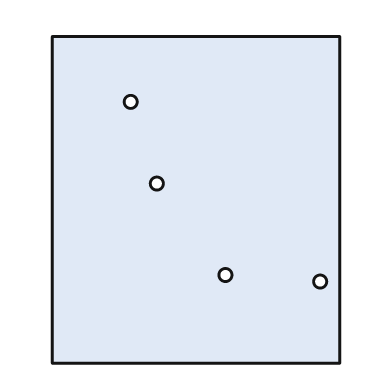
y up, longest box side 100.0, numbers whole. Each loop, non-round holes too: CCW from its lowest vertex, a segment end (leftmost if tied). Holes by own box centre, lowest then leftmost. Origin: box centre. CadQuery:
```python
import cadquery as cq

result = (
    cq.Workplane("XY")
    .moveTo(-44.0, -50.0)
    .lineTo(44.0, -50.0)
    .lineTo(44.0, 50.0)
    .lineTo(-44.0, 50.0)
    .close()
    .moveTo(38.0, -25.0)
    .circle(2.0)
    .moveTo(9.0, -23.0)
    .circle(2.0)
    .moveTo(-12.0, 5.0)
    .circle(2.0)
    .moveTo(-20.0, 30.0)
    .circle(2.0)
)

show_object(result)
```